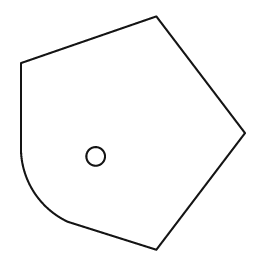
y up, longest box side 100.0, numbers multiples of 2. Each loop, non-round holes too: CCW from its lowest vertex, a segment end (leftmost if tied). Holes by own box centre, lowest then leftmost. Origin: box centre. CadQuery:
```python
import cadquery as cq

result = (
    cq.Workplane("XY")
    .moveTo(10.0, -50.0)
    .lineTo(48.0, 0.0)
    .lineTo(10.0, 50.0)
    .lineTo(-48.0, 30.0)
    .lineTo(-48.0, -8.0)
    .threePointArc((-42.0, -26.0), (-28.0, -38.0))
    .close()
    .moveTo(-16.0, -10.0)
    .circle(4.0)
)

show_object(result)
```